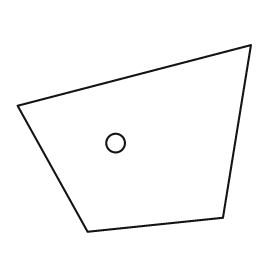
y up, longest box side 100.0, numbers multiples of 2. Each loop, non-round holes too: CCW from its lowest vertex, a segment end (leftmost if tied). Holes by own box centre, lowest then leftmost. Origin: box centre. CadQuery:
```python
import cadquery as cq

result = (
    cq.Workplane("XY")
    .moveTo(-20.0, -40.0)
    .lineTo(38.0, -34.0)
    .lineTo(50.0, 40.0)
    .lineTo(-50.0, 14.0)
    .close()
    .moveTo(-8.0, -2.0)
    .circle(4.0)
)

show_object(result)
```